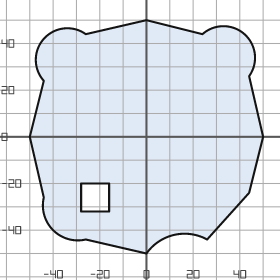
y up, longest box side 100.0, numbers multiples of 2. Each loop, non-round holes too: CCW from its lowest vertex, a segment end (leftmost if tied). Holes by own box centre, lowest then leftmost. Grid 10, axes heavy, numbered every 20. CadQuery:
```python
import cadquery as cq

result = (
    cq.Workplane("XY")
    .moveTo(0.0, -50.0)
    .threePointArc((12.0, -42.0), (26.0, -44.0))
    .lineTo(44.0, -24.0)
    .lineTo(50.0, 0.0)
    .lineTo(44.0, 26.0)
    .threePointArc((42.0, 44.0), (24.0, 44.0))
    .lineTo(0.0, 50.0)
    .lineTo(-26.0, 44.0)
    .threePointArc((-44.0, 42.0), (-44.0, 24.0))
    .lineTo(-50.0, 0.0)
    .lineTo(-44.0, -26.0)
    .threePointArc((-40.0, -40.0), (-26.0, -44.0))
    .close()
    .moveTo(-28.0, -32.0)
    .lineTo(-16.0, -32.0)
    .lineTo(-16.0, -20.0)
    .lineTo(-28.0, -20.0)
    .close()
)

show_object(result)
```